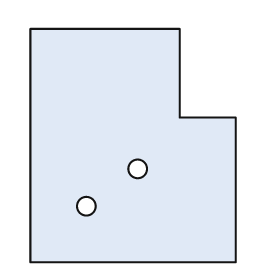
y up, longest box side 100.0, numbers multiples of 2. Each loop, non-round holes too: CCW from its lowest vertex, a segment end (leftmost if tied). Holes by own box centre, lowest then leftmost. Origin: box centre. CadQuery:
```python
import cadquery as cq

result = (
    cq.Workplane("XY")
    .moveTo(-44.0, -50.0)
    .lineTo(44.0, -50.0)
    .lineTo(44.0, 12.0)
    .lineTo(20.0, 12.0)
    .lineTo(20.0, 50.0)
    .lineTo(-44.0, 50.0)
    .close()
    .moveTo(-20.0, -26.0)
    .circle(4.0)
    .moveTo(2.0, -10.0)
    .circle(4.0)
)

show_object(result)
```